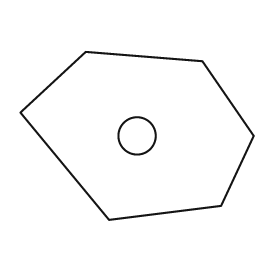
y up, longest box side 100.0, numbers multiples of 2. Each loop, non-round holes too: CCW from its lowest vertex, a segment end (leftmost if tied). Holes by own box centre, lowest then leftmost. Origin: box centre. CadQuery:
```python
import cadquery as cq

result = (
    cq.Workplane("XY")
    .moveTo(-12.0, -36.0)
    .lineTo(36.0, -30.0)
    .lineTo(50.0, 0.0)
    .lineTo(28.0, 32.0)
    .lineTo(-22.0, 36.0)
    .lineTo(-50.0, 10.0)
    .close()
    .moveTo(0.0, 0.0)
    .circle(8.0)
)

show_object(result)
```